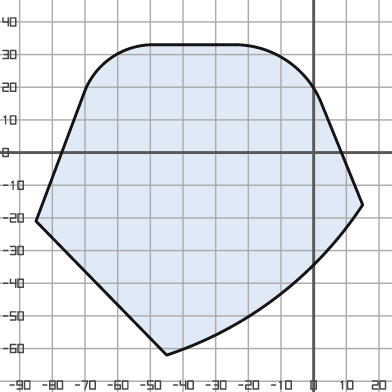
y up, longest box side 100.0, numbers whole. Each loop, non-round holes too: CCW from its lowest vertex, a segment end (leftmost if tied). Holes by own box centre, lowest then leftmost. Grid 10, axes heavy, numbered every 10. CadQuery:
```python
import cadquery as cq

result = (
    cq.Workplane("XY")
    .moveTo(-45.0, -62.0)
    .threePointArc((-11.0, -44.0), (15.0, -16.0))
    .lineTo(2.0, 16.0)
    .threePointArc((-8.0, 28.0), (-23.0, 33.0))
    .lineTo(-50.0, 33.0)
    .threePointArc((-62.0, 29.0), (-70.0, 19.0))
    .lineTo(-85.0, -21.0)
    .close()
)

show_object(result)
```